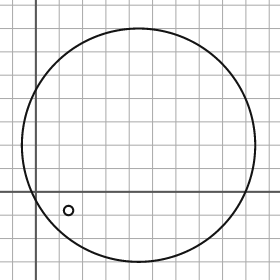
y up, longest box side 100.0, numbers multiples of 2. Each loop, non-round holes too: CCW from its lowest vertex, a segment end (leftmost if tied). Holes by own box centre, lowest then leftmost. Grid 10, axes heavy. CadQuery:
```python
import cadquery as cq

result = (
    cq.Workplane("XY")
    .moveTo(44.0, 20.0)
    .circle(50.0)
    .moveTo(14.0, -8.0)
    .circle(2.0)
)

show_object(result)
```